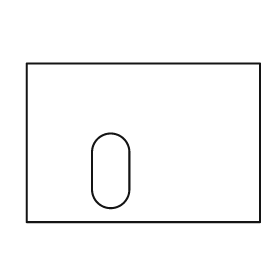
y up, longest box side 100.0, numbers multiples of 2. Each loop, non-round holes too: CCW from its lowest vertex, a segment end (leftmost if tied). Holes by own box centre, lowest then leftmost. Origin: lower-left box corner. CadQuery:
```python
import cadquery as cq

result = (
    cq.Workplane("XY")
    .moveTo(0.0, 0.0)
    .lineTo(100.0, 0.0)
    .lineTo(100.0, 68.0)
    .lineTo(0.0, 68.0)
    .close()
    .moveTo(28.0, 14.0)
    .threePointArc((36.0, 6.0), (44.0, 14.0))
    .lineTo(44.0, 30.0)
    .threePointArc((36.0, 38.0), (28.0, 30.0))
    .close()
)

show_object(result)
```